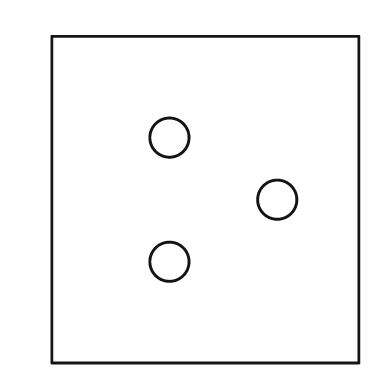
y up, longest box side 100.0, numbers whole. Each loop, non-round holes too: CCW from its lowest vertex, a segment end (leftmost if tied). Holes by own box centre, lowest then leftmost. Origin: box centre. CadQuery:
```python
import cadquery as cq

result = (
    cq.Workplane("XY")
    .moveTo(-47.0, -50.0)
    .lineTo(47.0, -50.0)
    .lineTo(47.0, 50.0)
    .lineTo(-47.0, 50.0)
    .close()
    .moveTo(-11.0, -19.0)
    .circle(6.0)
    .moveTo(22.0, 0.0)
    .circle(6.0)
    .moveTo(-11.0, 19.0)
    .circle(6.0)
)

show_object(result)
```